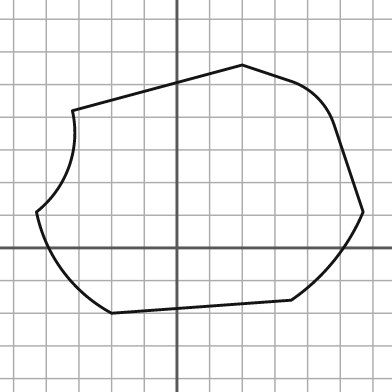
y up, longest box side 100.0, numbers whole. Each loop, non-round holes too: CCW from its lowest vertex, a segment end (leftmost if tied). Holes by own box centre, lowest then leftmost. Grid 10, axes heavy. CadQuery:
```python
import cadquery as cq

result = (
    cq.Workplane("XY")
    .moveTo(-20.0, -20.0)
    .lineTo(35.0, -16.0)
    .threePointArc((48.0, -4.0), (57.0, 11.0))
    .lineTo(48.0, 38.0)
    .threePointArc((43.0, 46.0), (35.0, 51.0))
    .lineTo(20.0, 56.0)
    .lineTo(-32.0, 42.0)
    .threePointArc((-33.0, 25.0), (-43.0, 11.0))
    .threePointArc((-35.0, -7.0), (-20.0, -20.0))
    .close()
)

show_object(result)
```